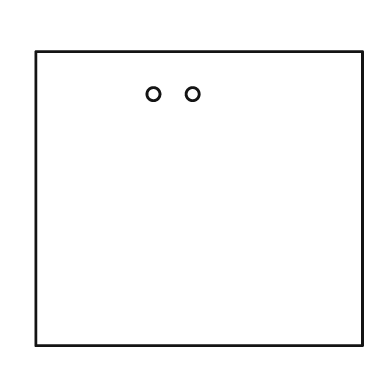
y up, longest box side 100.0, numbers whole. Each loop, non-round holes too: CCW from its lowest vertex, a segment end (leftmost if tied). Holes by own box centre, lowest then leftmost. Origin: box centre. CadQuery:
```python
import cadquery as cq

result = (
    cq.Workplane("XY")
    .moveTo(-50.0, -45.0)
    .lineTo(50.0, -45.0)
    .lineTo(50.0, 45.0)
    .lineTo(-50.0, 45.0)
    .close()
    .moveTo(-14.0, 32.0)
    .circle(2.0)
    .moveTo(-2.0, 32.0)
    .circle(2.0)
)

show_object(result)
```